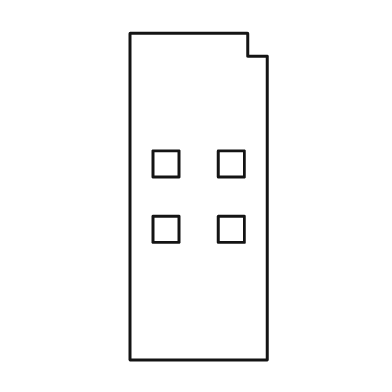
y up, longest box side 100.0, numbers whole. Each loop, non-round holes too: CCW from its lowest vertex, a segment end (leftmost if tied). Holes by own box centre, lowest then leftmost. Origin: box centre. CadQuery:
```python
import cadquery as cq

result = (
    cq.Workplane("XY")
    .moveTo(-21.0, -50.0)
    .lineTo(21.0, -50.0)
    .lineTo(21.0, 43.0)
    .lineTo(15.0, 43.0)
    .lineTo(15.0, 50.0)
    .lineTo(-21.0, 50.0)
    .close()
    .moveTo(-14.0, -14.0)
    .lineTo(-6.0, -14.0)
    .lineTo(-6.0, -6.0)
    .lineTo(-14.0, -6.0)
    .close()
    .moveTo(6.0, -14.0)
    .lineTo(14.0, -14.0)
    .lineTo(14.0, -6.0)
    .lineTo(6.0, -6.0)
    .close()
    .moveTo(-14.0, 6.0)
    .lineTo(-6.0, 6.0)
    .lineTo(-6.0, 14.0)
    .lineTo(-14.0, 14.0)
    .close()
    .moveTo(6.0, 6.0)
    .lineTo(14.0, 6.0)
    .lineTo(14.0, 14.0)
    .lineTo(6.0, 14.0)
    .close()
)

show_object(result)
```